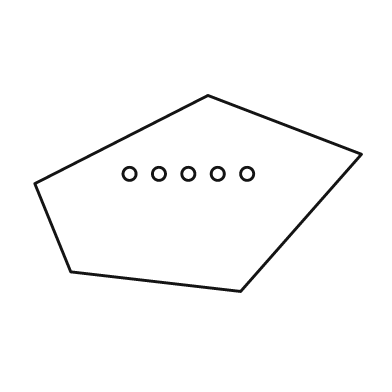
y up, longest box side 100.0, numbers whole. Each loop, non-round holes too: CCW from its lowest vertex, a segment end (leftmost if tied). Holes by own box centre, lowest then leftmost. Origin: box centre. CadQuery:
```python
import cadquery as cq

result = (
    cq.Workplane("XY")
    .moveTo(13.0, -30.0)
    .lineTo(50.0, 12.0)
    .lineTo(3.0, 30.0)
    .lineTo(-50.0, 3.0)
    .lineTo(-39.0, -24.0)
    .close()
    .moveTo(-21.0, 6.0)
    .circle(2.0)
    .moveTo(-12.0, 6.0)
    .circle(2.0)
    .moveTo(-3.0, 6.0)
    .circle(2.0)
    .moveTo(6.0, 6.0)
    .circle(2.0)
    .moveTo(15.0, 6.0)
    .circle(2.0)
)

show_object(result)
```